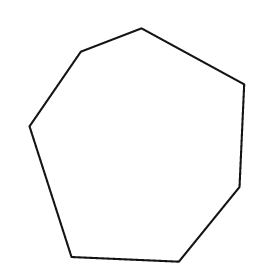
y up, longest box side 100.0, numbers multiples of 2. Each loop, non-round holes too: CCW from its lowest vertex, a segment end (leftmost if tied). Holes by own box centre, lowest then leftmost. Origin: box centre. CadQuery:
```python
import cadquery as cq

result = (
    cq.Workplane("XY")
    .moveTo(18.0, -50.0)
    .lineTo(44.0, -18.0)
    .lineTo(46.0, 26.0)
    .lineTo(2.0, 50.0)
    .lineTo(-24.0, 40.0)
    .lineTo(-46.0, 8.0)
    .lineTo(-28.0, -48.0)
    .close()
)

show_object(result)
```